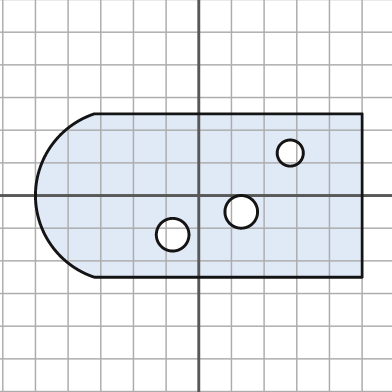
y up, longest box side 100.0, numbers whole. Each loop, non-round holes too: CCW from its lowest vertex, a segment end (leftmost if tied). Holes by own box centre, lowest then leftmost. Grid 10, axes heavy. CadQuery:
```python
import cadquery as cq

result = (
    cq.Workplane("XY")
    .moveTo(-32.0, -25.0)
    .lineTo(50.0, -25.0)
    .lineTo(50.0, 25.0)
    .lineTo(-32.0, 25.0)
    .threePointArc((-50.0, 0.0), (-32.0, -25.0))
    .close()
    .moveTo(-8.0, -12.0)
    .circle(5.0)
    .moveTo(13.0, -5.0)
    .circle(5.0)
    .moveTo(28.0, 13.0)
    .circle(4.0)
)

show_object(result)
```